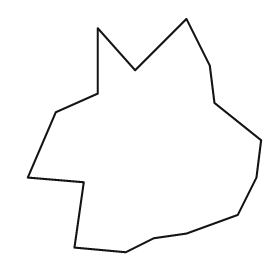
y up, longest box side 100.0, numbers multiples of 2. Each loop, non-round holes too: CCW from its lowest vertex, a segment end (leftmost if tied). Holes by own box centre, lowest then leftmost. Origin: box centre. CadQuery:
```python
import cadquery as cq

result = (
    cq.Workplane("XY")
    .moveTo(-8.0, -50.0)
    .lineTo(4.0, -44.0)
    .lineTo(18.0, -42.0)
    .lineTo(40.0, -34.0)
    .lineTo(48.0, -18.0)
    .lineTo(50.0, -2.0)
    .lineTo(30.0, 14.0)
    .lineTo(28.0, 30.0)
    .lineTo(18.0, 50.0)
    .lineTo(-4.0, 28.0)
    .lineTo(-20.0, 46.0)
    .lineTo(-20.0, 18.0)
    .lineTo(-38.0, 10.0)
    .lineTo(-50.0, -18.0)
    .lineTo(-26.0, -20.0)
    .lineTo(-30.0, -48.0)
    .close()
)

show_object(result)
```